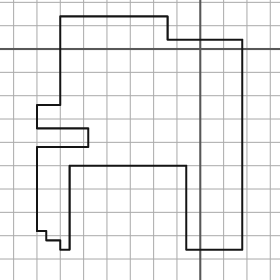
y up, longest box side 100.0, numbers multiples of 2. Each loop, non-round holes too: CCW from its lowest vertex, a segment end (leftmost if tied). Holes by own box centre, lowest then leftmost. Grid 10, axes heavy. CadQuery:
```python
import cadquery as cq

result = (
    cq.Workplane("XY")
    .moveTo(-60.0, -86.0)
    .lineTo(-56.0, -86.0)
    .lineTo(-56.0, -50.0)
    .lineTo(-6.0, -50.0)
    .lineTo(-6.0, -86.0)
    .lineTo(18.0, -86.0)
    .lineTo(18.0, 4.0)
    .lineTo(-14.0, 4.0)
    .lineTo(-14.0, 14.0)
    .lineTo(-60.0, 14.0)
    .lineTo(-60.0, -24.0)
    .lineTo(-70.0, -24.0)
    .lineTo(-70.0, -34.0)
    .lineTo(-48.0, -34.0)
    .lineTo(-48.0, -42.0)
    .lineTo(-70.0, -42.0)
    .lineTo(-70.0, -78.0)
    .lineTo(-66.0, -78.0)
    .lineTo(-66.0, -82.0)
    .lineTo(-60.0, -82.0)
    .close()
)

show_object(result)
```